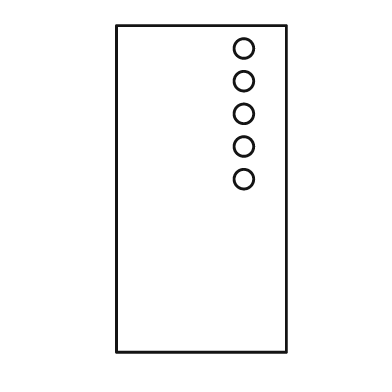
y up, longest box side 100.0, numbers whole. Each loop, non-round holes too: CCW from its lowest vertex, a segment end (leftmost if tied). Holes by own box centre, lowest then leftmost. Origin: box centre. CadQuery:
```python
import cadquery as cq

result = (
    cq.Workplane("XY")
    .moveTo(-26.0, -50.0)
    .lineTo(26.0, -50.0)
    .lineTo(26.0, 50.0)
    .lineTo(-26.0, 50.0)
    .close()
    .moveTo(13.0, 3.0)
    .circle(3.0)
    .moveTo(13.0, 13.0)
    .circle(3.0)
    .moveTo(13.0, 23.0)
    .circle(3.0)
    .moveTo(13.0, 33.0)
    .circle(3.0)
    .moveTo(13.0, 43.0)
    .circle(3.0)
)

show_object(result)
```